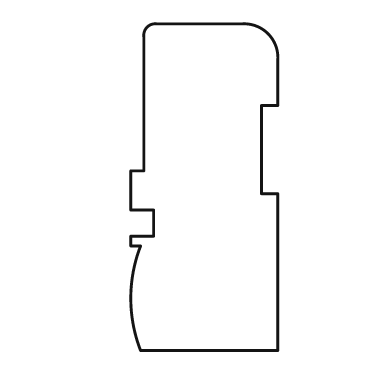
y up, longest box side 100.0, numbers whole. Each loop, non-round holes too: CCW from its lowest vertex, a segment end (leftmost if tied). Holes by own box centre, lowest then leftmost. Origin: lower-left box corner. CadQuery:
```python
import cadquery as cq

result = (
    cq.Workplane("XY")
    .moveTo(3.0, 0.0)
    .lineTo(45.0, 0.0)
    .lineTo(45.0, 48.0)
    .lineTo(40.0, 48.0)
    .lineTo(40.0, 75.0)
    .lineTo(45.0, 75.0)
    .lineTo(45.0, 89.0)
    .threePointArc((42.0, 97.0), (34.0, 100.0))
    .lineTo(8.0, 100.0)
    .threePointArc((5.0, 99.0), (4.0, 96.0))
    .lineTo(4.0, 55.0)
    .lineTo(0.0, 55.0)
    .lineTo(0.0, 43.0)
    .lineTo(7.0, 43.0)
    .lineTo(7.0, 35.0)
    .lineTo(0.0, 35.0)
    .lineTo(0.0, 32.0)
    .lineTo(3.0, 32.0)
    .threePointArc((0.0, 16.0), (3.0, 0.0))
    .close()
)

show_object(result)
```